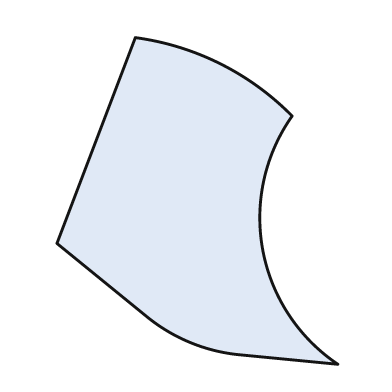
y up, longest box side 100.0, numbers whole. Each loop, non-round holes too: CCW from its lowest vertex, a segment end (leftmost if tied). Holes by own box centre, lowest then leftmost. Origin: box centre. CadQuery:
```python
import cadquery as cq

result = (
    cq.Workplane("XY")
    .moveTo(43.0, -50.0)
    .threePointArc((20.0, -15.0), (29.0, 26.0))
    .threePointArc((7.0, 42.0), (-19.0, 50.0))
    .lineTo(-43.0, -13.0)
    .lineTo(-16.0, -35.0)
    .threePointArc((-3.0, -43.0), (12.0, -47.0))
    .close()
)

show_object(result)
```